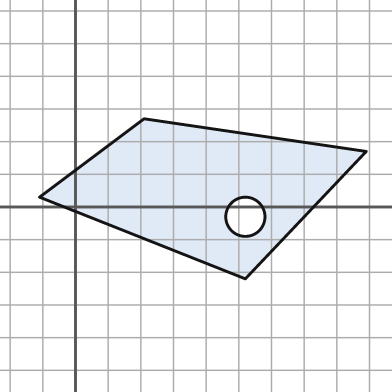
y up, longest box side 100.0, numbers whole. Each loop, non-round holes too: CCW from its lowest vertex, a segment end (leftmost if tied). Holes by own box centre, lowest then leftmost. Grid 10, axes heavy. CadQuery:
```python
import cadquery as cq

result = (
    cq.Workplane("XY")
    .moveTo(52.0, -22.0)
    .lineTo(89.0, 17.0)
    .lineTo(21.0, 27.0)
    .lineTo(-11.0, 3.0)
    .close()
    .moveTo(52.0, -3.0)
    .circle(6.0)
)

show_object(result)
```